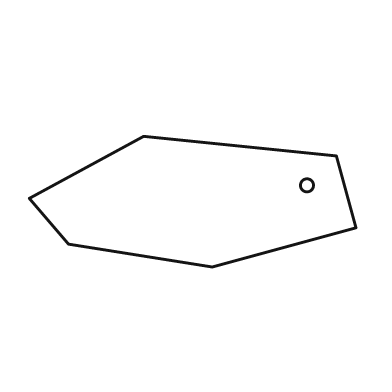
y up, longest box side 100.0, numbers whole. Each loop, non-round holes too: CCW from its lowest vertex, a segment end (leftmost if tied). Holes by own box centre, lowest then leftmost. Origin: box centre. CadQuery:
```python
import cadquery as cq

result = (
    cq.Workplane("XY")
    .moveTo(6.0, -20.0)
    .lineTo(50.0, -8.0)
    .lineTo(44.0, 14.0)
    .lineTo(-15.0, 20.0)
    .lineTo(-50.0, 1.0)
    .lineTo(-38.0, -13.0)
    .close()
    .moveTo(35.0, 5.0)
    .circle(2.0)
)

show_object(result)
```